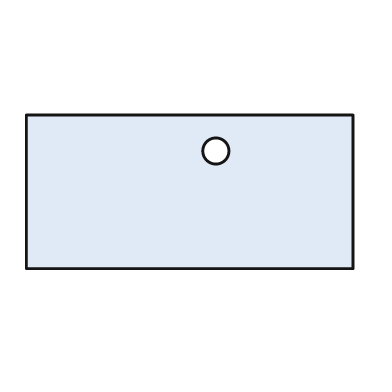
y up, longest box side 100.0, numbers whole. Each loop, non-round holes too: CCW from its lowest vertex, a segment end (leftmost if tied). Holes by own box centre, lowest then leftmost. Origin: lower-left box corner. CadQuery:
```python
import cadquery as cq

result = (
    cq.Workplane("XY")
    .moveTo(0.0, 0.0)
    .lineTo(100.0, 0.0)
    .lineTo(100.0, 47.0)
    .lineTo(0.0, 47.0)
    .close()
    .moveTo(58.0, 36.0)
    .circle(4.0)
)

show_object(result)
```